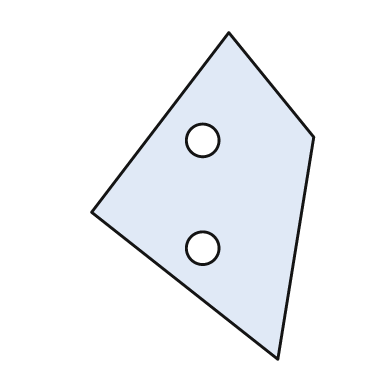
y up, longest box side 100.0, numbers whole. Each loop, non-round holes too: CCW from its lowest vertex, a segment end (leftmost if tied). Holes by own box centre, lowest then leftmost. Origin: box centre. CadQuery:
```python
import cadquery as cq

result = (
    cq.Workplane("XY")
    .moveTo(23.0, -50.0)
    .lineTo(34.0, 18.0)
    .lineTo(8.0, 50.0)
    .lineTo(-34.0, -5.0)
    .close()
    .moveTo(0.0, -16.0)
    .circle(5.0)
    .moveTo(0.0, 17.0)
    .circle(5.0)
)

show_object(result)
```